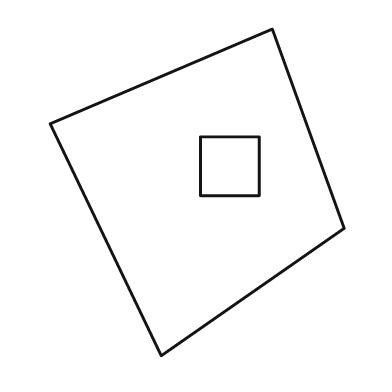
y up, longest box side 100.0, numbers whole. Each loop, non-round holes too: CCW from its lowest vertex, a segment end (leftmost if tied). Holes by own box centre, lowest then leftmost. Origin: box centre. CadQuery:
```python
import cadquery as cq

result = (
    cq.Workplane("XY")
    .moveTo(-11.0, -50.0)
    .lineTo(45.0, -11.0)
    .lineTo(23.0, 50.0)
    .lineTo(-45.0, 21.0)
    .close()
    .moveTo(1.0, -1.0)
    .lineTo(19.0, -1.0)
    .lineTo(19.0, 17.0)
    .lineTo(1.0, 17.0)
    .close()
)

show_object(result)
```